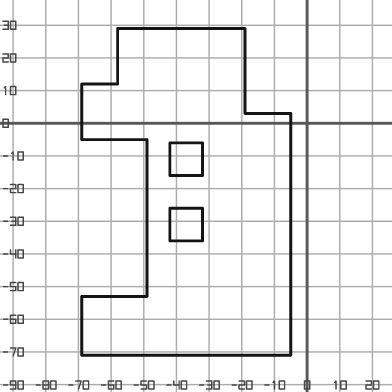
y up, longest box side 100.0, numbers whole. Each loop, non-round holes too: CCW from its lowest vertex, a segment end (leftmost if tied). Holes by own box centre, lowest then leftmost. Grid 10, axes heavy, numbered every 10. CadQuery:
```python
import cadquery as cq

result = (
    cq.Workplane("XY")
    .moveTo(-69.0, -71.0)
    .lineTo(-5.0, -71.0)
    .lineTo(-5.0, 3.0)
    .lineTo(-19.0, 3.0)
    .lineTo(-19.0, 29.0)
    .lineTo(-58.0, 29.0)
    .lineTo(-58.0, 12.0)
    .lineTo(-69.0, 12.0)
    .lineTo(-69.0, -5.0)
    .lineTo(-49.0, -5.0)
    .lineTo(-49.0, -53.0)
    .lineTo(-69.0, -53.0)
    .close()
    .moveTo(-42.0, -36.0)
    .lineTo(-32.0, -36.0)
    .lineTo(-32.0, -26.0)
    .lineTo(-42.0, -26.0)
    .close()
    .moveTo(-42.0, -16.0)
    .lineTo(-32.0, -16.0)
    .lineTo(-32.0, -6.0)
    .lineTo(-42.0, -6.0)
    .close()
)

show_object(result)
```